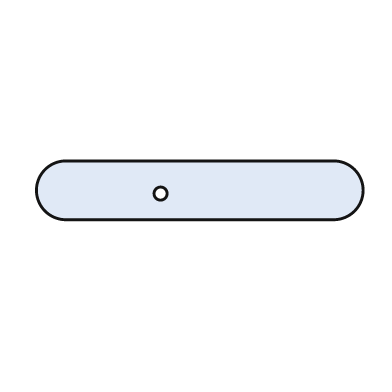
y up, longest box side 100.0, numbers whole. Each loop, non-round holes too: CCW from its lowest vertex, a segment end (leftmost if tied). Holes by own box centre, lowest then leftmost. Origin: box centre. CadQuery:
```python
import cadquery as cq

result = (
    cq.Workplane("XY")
    .moveTo(-41.0, -9.0)
    .lineTo(41.0, -9.0)
    .threePointArc((50.0, 0.0), (41.0, 9.0))
    .lineTo(-41.0, 9.0)
    .threePointArc((-50.0, 0.0), (-41.0, -9.0))
    .close()
    .moveTo(-12.0, -1.0)
    .circle(2.0)
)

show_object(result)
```